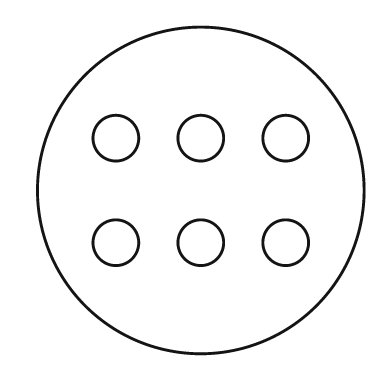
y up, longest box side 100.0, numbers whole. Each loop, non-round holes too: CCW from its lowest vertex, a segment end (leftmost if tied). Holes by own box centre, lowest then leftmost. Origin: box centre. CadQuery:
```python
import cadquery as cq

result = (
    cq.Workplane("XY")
    .moveTo(0.0, 0.0)
    .circle(50.0)
    .moveTo(-26.0, -16.0)
    .circle(7.0)
    .moveTo(0.0, -16.0)
    .circle(7.0)
    .moveTo(26.0, -16.0)
    .circle(7.0)
    .moveTo(-26.0, 16.0)
    .circle(7.0)
    .moveTo(0.0, 16.0)
    .circle(7.0)
    .moveTo(26.0, 16.0)
    .circle(7.0)
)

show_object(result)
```